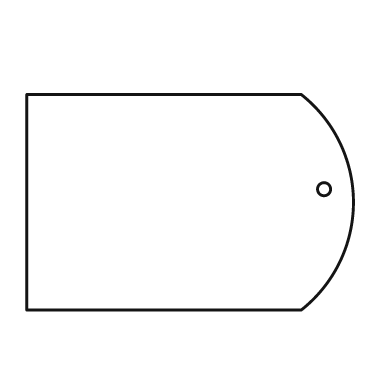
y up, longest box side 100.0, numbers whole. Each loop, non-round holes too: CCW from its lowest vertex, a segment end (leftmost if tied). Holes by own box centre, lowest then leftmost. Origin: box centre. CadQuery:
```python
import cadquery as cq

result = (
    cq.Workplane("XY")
    .moveTo(-50.0, -33.0)
    .lineTo(34.0, -33.0)
    .threePointArc((50.0, 0.0), (34.0, 33.0))
    .lineTo(-50.0, 33.0)
    .close()
    .moveTo(41.0, 4.0)
    .circle(2.0)
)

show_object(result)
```